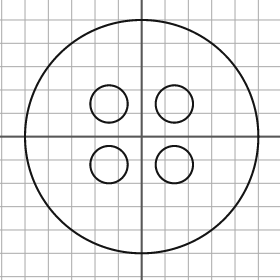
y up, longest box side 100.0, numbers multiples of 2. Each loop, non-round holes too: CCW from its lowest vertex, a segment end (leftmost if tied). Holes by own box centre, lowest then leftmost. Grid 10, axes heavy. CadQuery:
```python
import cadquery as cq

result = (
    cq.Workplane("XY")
    .moveTo(0.0, 0.0)
    .circle(50.0)
    .moveTo(-14.0, -12.0)
    .circle(8.0)
    .moveTo(14.0, -12.0)
    .circle(8.0)
    .moveTo(-14.0, 14.0)
    .circle(8.0)
    .moveTo(14.0, 14.0)
    .circle(8.0)
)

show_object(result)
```